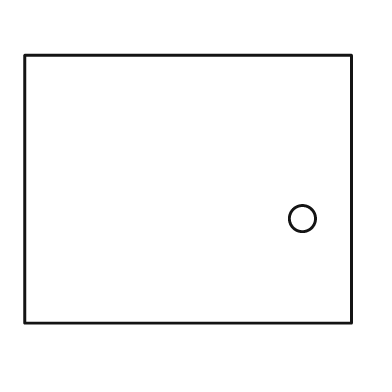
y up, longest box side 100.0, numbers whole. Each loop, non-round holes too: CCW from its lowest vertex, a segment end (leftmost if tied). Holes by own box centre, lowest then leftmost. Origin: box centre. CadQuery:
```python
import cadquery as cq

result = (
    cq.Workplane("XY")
    .moveTo(-50.0, -41.0)
    .lineTo(50.0, -41.0)
    .lineTo(50.0, 41.0)
    .lineTo(-50.0, 41.0)
    .close()
    .moveTo(35.0, -9.0)
    .circle(4.0)
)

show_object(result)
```